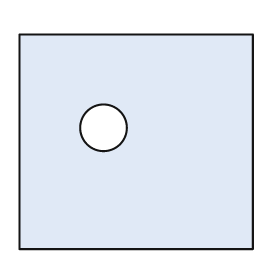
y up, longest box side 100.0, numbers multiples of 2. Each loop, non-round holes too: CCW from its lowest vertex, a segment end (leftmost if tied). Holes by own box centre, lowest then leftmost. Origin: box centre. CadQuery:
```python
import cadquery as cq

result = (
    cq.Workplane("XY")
    .moveTo(-50.0, -46.0)
    .lineTo(50.0, -46.0)
    .lineTo(50.0, 46.0)
    .lineTo(-50.0, 46.0)
    .close()
    .moveTo(-14.0, 6.0)
    .circle(10.0)
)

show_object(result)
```